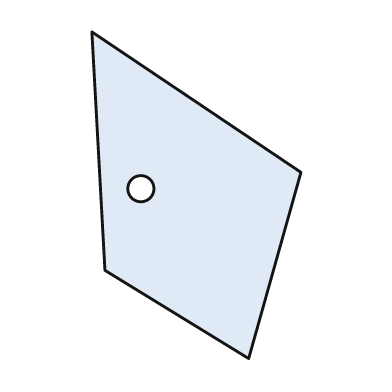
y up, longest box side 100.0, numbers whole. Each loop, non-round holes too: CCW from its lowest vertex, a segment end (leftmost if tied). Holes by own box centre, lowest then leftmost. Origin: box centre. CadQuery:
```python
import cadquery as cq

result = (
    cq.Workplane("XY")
    .moveTo(16.0, -50.0)
    .lineTo(32.0, 7.0)
    .lineTo(-32.0, 50.0)
    .lineTo(-28.0, -23.0)
    .close()
    .moveTo(-17.0, 2.0)
    .circle(4.0)
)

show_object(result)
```